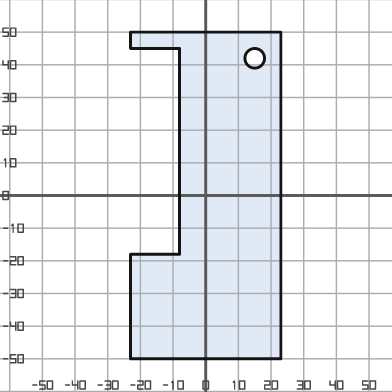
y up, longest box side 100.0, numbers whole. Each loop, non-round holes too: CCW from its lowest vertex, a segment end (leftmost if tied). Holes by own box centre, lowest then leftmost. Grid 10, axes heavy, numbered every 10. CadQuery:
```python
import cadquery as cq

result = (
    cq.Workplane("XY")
    .moveTo(-23.0, -50.0)
    .lineTo(23.0, -50.0)
    .lineTo(23.0, 50.0)
    .lineTo(-23.0, 50.0)
    .lineTo(-23.0, 45.0)
    .lineTo(-8.0, 45.0)
    .lineTo(-8.0, -18.0)
    .lineTo(-23.0, -18.0)
    .close()
    .moveTo(15.0, 42.0)
    .circle(3.0)
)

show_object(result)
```